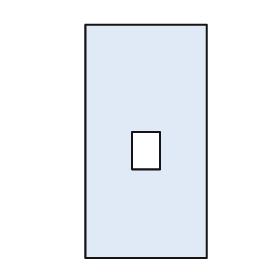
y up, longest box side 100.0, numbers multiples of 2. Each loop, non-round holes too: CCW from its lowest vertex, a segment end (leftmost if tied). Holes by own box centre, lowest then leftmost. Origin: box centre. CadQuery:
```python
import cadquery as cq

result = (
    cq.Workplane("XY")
    .moveTo(-26.0, -50.0)
    .lineTo(26.0, -50.0)
    .lineTo(26.0, 50.0)
    .lineTo(-26.0, 50.0)
    .close()
    .moveTo(-6.0, -12.0)
    .lineTo(6.0, -12.0)
    .lineTo(6.0, 4.0)
    .lineTo(-6.0, 4.0)
    .close()
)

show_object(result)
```